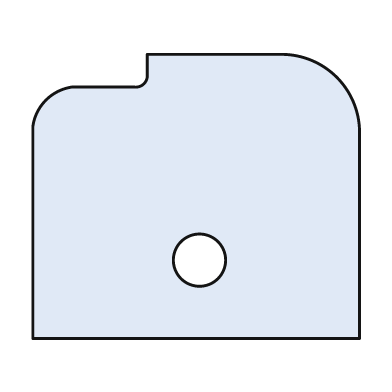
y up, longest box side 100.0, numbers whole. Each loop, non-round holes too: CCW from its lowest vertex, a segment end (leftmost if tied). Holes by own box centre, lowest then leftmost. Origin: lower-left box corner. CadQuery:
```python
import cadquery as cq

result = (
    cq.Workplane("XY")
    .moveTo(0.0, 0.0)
    .lineTo(100.0, 0.0)
    .lineTo(100.0, 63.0)
    .threePointArc((93.0, 80.0), (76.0, 87.0))
    .lineTo(35.0, 87.0)
    .lineTo(35.0, 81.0)
    .threePointArc((34.0, 78.0), (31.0, 77.0))
    .lineTo(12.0, 77.0)
    .threePointArc((4.0, 73.0), (0.0, 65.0))
    .close()
    .moveTo(51.0, 24.0)
    .circle(8.0)
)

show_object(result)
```